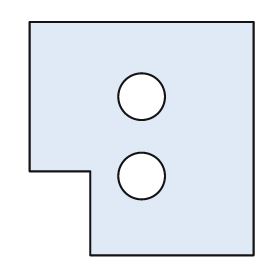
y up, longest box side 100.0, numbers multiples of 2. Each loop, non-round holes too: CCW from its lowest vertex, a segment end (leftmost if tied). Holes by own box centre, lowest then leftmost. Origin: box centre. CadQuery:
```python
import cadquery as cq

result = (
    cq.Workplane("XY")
    .moveTo(-22.0, -50.0)
    .lineTo(48.0, -50.0)
    .lineTo(48.0, 50.0)
    .lineTo(-48.0, 50.0)
    .lineTo(-48.0, -14.0)
    .lineTo(-22.0, -14.0)
    .close()
    .moveTo(0.0, -16.0)
    .circle(10.0)
    .moveTo(0.0, 18.0)
    .circle(10.0)
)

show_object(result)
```